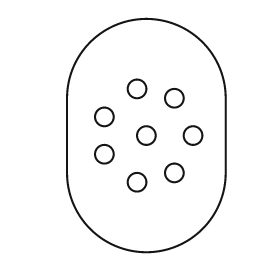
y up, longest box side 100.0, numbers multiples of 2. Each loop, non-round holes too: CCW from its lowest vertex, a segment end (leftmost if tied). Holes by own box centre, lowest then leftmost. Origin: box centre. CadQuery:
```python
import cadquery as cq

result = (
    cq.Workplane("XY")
    .moveTo(-34.0, -16.0)
    .threePointArc((0.0, -50.0), (34.0, -16.0))
    .lineTo(34.0, 16.0)
    .threePointArc((0.0, 50.0), (-34.0, 16.0))
    .close()
    .moveTo(-4.0, -20.0)
    .circle(4.0)
    .moveTo(12.0, -16.0)
    .circle(4.0)
    .moveTo(-18.0, -8.0)
    .circle(4.0)
    .moveTo(0.0, 0.0)
    .circle(4.0)
    .moveTo(20.0, 0.0)
    .circle(4.0)
    .moveTo(-18.0, 8.0)
    .circle(4.0)
    .moveTo(12.0, 16.0)
    .circle(4.0)
    .moveTo(-4.0, 20.0)
    .circle(4.0)
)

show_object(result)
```